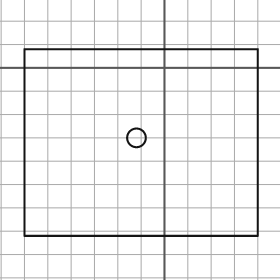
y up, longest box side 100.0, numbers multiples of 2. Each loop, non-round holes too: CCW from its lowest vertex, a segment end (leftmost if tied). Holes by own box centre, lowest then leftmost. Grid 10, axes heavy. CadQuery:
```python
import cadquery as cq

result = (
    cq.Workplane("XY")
    .moveTo(-60.0, -72.0)
    .lineTo(40.0, -72.0)
    .lineTo(40.0, 8.0)
    .lineTo(-60.0, 8.0)
    .close()
    .moveTo(-12.0, -30.0)
    .circle(4.0)
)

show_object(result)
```